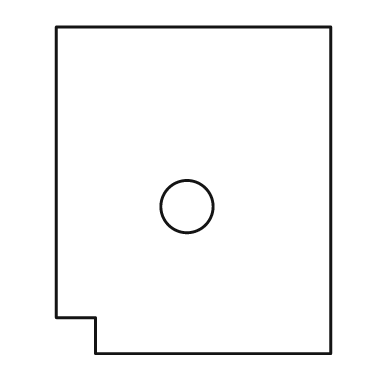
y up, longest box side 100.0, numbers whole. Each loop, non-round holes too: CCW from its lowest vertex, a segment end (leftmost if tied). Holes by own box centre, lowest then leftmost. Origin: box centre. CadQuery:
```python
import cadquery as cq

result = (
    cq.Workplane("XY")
    .moveTo(-30.0, -50.0)
    .lineTo(42.0, -50.0)
    .lineTo(42.0, 50.0)
    .lineTo(-42.0, 50.0)
    .lineTo(-42.0, -39.0)
    .lineTo(-30.0, -39.0)
    .close()
    .moveTo(-2.0, -5.0)
    .circle(8.0)
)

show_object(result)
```